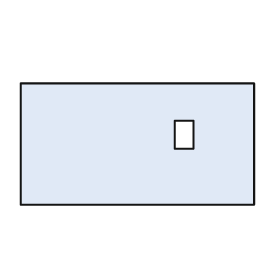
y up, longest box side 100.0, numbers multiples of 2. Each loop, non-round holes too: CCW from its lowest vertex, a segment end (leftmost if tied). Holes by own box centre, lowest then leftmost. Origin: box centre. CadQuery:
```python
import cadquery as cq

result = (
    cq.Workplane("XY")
    .moveTo(-50.0, -26.0)
    .lineTo(50.0, -26.0)
    .lineTo(50.0, 26.0)
    .lineTo(-50.0, 26.0)
    .close()
    .moveTo(16.0, -2.0)
    .lineTo(24.0, -2.0)
    .lineTo(24.0, 10.0)
    .lineTo(16.0, 10.0)
    .close()
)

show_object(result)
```